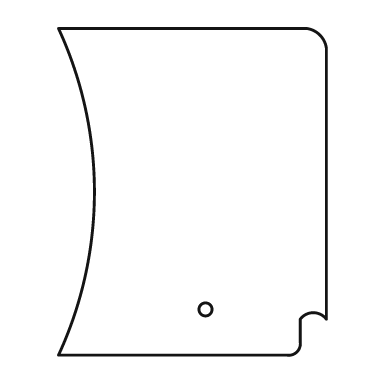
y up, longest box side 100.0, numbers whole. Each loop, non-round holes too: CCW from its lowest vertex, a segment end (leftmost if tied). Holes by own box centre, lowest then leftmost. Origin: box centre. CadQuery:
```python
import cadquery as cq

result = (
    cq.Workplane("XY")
    .moveTo(-41.0, -50.0)
    .lineTo(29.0, -50.0)
    .threePointArc((32.0, -49.0), (33.0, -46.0))
    .lineTo(33.0, -39.0)
    .threePointArc((37.0, -37.0), (41.0, -39.0))
    .lineTo(41.0, 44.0)
    .threePointArc((39.0, 48.0), (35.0, 50.0))
    .lineTo(-41.0, 50.0)
    .threePointArc((-30.0, 0.0), (-41.0, -50.0))
    .close()
    .moveTo(4.0, -36.0)
    .circle(2.0)
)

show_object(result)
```